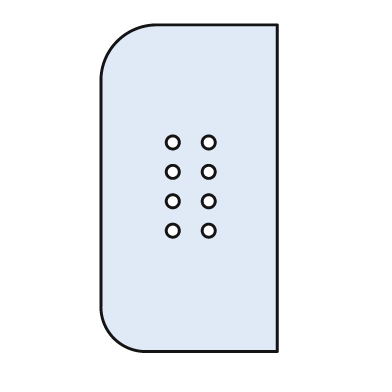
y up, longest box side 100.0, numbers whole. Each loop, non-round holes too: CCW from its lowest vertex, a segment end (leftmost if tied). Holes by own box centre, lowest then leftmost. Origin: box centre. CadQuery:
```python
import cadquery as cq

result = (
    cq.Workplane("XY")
    .moveTo(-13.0, -50.0)
    .lineTo(27.0, -50.0)
    .lineTo(27.0, 50.0)
    .lineTo(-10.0, 50.0)
    .threePointArc((-22.0, 45.0), (-27.0, 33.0))
    .lineTo(-27.0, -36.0)
    .threePointArc((-23.0, -46.0), (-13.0, -50.0))
    .close()
    .moveTo(-5.0, -13.0)
    .circle(2.0)
    .moveTo(6.0, -13.0)
    .circle(2.0)
    .moveTo(-5.0, -4.0)
    .circle(2.0)
    .moveTo(6.0, -4.0)
    .circle(2.0)
    .moveTo(-5.0, 5.0)
    .circle(2.0)
    .moveTo(6.0, 5.0)
    .circle(2.0)
    .moveTo(-5.0, 14.0)
    .circle(2.0)
    .moveTo(6.0, 14.0)
    .circle(2.0)
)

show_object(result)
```